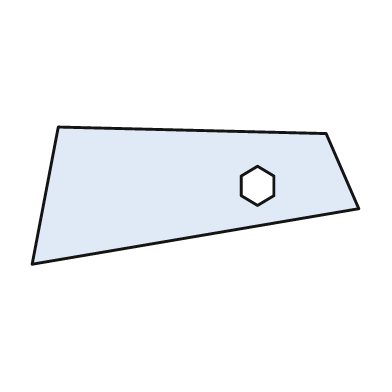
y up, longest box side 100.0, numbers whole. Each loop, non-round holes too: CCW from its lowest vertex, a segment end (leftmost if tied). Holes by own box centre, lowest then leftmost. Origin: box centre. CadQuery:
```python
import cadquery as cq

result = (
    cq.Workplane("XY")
    .moveTo(-50.0, -21.0)
    .lineTo(50.0, -4.0)
    .lineTo(40.0, 19.0)
    .lineTo(-42.0, 21.0)
    .close()
    .moveTo(19.0, -3.0)
    .lineTo(24.0, 0.0)
    .lineTo(24.0, 6.0)
    .lineTo(19.0, 9.0)
    .lineTo(14.0, 6.0)
    .lineTo(14.0, 0.0)
    .close()
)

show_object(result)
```